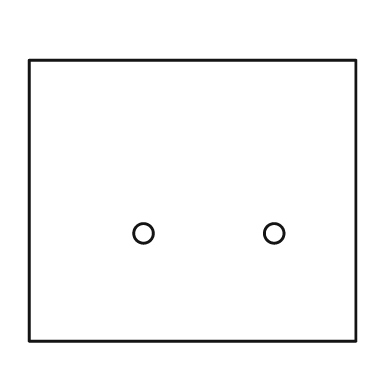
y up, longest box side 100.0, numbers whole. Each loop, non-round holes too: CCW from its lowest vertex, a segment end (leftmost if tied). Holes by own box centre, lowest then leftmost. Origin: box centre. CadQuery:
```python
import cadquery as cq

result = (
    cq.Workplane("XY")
    .moveTo(-50.0, -43.0)
    .lineTo(50.0, -43.0)
    .lineTo(50.0, 43.0)
    .lineTo(-50.0, 43.0)
    .close()
    .moveTo(-15.0, -10.0)
    .circle(3.0)
    .moveTo(25.0, -10.0)
    .circle(3.0)
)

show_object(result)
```